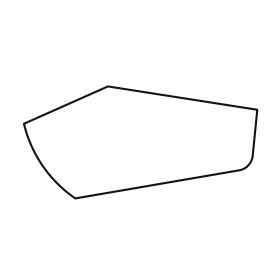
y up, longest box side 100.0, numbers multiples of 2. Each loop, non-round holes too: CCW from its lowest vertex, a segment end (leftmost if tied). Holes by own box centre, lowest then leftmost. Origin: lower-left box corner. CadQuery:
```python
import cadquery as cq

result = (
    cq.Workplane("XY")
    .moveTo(22.0, 0.0)
    .lineTo(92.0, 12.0)
    .threePointArc((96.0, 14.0), (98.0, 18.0))
    .lineTo(100.0, 38.0)
    .lineTo(36.0, 48.0)
    .lineTo(0.0, 32.0)
    .threePointArc((8.0, 14.0), (22.0, 0.0))
    .close()
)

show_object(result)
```